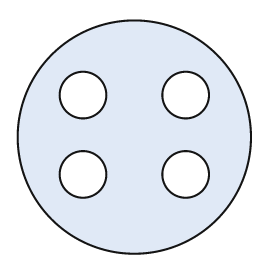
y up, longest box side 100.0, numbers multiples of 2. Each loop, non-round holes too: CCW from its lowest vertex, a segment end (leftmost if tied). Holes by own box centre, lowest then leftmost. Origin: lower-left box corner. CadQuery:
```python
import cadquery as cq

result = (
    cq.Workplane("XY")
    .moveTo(50.0, 50.0)
    .circle(50.0)
    .moveTo(28.0, 34.0)
    .circle(10.0)
    .moveTo(72.0, 34.0)
    .circle(10.0)
    .moveTo(28.0, 68.0)
    .circle(10.0)
    .moveTo(72.0, 68.0)
    .circle(10.0)
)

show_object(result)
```